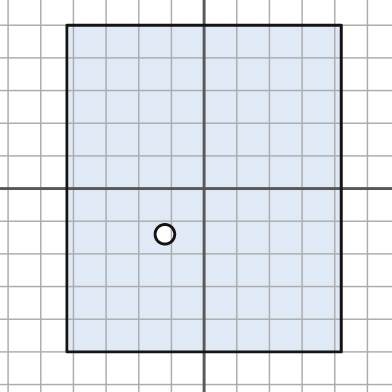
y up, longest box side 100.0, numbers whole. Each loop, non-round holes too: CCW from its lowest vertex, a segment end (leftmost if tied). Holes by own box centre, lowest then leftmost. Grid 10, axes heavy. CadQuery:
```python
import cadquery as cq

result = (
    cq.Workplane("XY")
    .moveTo(-42.0, -50.0)
    .lineTo(42.0, -50.0)
    .lineTo(42.0, 50.0)
    .lineTo(-42.0, 50.0)
    .close()
    .moveTo(-12.0, -14.0)
    .circle(3.0)
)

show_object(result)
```